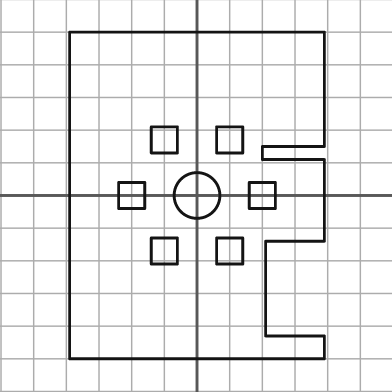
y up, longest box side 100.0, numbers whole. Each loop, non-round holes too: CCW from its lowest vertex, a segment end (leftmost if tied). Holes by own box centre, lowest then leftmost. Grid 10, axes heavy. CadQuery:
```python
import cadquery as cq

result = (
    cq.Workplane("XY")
    .moveTo(-39.0, -50.0)
    .lineTo(39.0, -50.0)
    .lineTo(39.0, -43.0)
    .lineTo(21.0, -43.0)
    .lineTo(21.0, -14.0)
    .lineTo(39.0, -14.0)
    .lineTo(39.0, 11.0)
    .lineTo(20.0, 11.0)
    .lineTo(20.0, 15.0)
    .lineTo(39.0, 15.0)
    .lineTo(39.0, 50.0)
    .lineTo(-39.0, 50.0)
    .close()
    .moveTo(-14.0, -21.0)
    .lineTo(-6.0, -21.0)
    .lineTo(-6.0, -13.0)
    .lineTo(-14.0, -13.0)
    .close()
    .moveTo(6.0, -21.0)
    .lineTo(14.0, -21.0)
    .lineTo(14.0, -13.0)
    .lineTo(6.0, -13.0)
    .close()
    .moveTo(-24.0, -4.0)
    .lineTo(-16.0, -4.0)
    .lineTo(-16.0, 4.0)
    .lineTo(-24.0, 4.0)
    .close()
    .moveTo(0.0, 0.0)
    .circle(7.0)
    .moveTo(16.0, -4.0)
    .lineTo(24.0, -4.0)
    .lineTo(24.0, 4.0)
    .lineTo(16.0, 4.0)
    .close()
    .moveTo(-14.0, 13.0)
    .lineTo(-6.0, 13.0)
    .lineTo(-6.0, 21.0)
    .lineTo(-14.0, 21.0)
    .close()
    .moveTo(6.0, 13.0)
    .lineTo(14.0, 13.0)
    .lineTo(14.0, 21.0)
    .lineTo(6.0, 21.0)
    .close()
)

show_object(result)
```